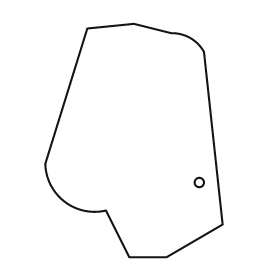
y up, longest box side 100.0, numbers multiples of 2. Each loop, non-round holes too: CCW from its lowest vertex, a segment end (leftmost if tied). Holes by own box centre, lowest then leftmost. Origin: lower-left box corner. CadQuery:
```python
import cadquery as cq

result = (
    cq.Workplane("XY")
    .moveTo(36.0, 0.0)
    .lineTo(52.0, 0.0)
    .lineTo(76.0, 14.0)
    .lineTo(68.0, 88.0)
    .threePointArc((62.0, 94.0), (54.0, 96.0))
    .lineTo(38.0, 100.0)
    .lineTo(18.0, 98.0)
    .lineTo(0.0, 40.0)
    .threePointArc((8.0, 24.0), (26.0, 20.0))
    .close()
    .moveTo(66.0, 32.0)
    .circle(2.0)
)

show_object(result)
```